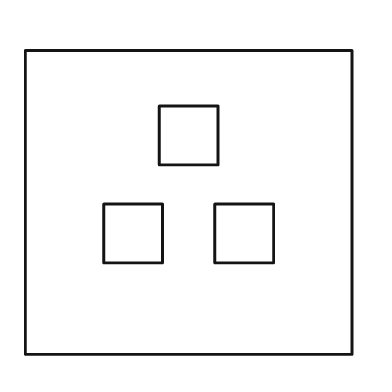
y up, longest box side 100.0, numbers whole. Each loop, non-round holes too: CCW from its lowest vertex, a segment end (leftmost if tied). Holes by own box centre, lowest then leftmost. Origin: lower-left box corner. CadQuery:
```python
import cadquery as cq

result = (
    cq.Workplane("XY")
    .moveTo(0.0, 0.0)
    .lineTo(100.0, 0.0)
    .lineTo(100.0, 93.0)
    .lineTo(0.0, 93.0)
    .close()
    .moveTo(24.0, 28.0)
    .lineTo(42.0, 28.0)
    .lineTo(42.0, 46.0)
    .lineTo(24.0, 46.0)
    .close()
    .moveTo(58.0, 28.0)
    .lineTo(76.0, 28.0)
    .lineTo(76.0, 46.0)
    .lineTo(58.0, 46.0)
    .close()
    .moveTo(41.0, 58.0)
    .lineTo(59.0, 58.0)
    .lineTo(59.0, 76.0)
    .lineTo(41.0, 76.0)
    .close()
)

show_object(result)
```